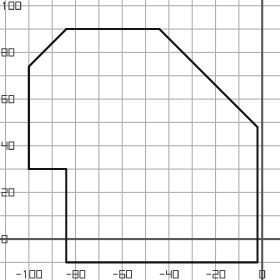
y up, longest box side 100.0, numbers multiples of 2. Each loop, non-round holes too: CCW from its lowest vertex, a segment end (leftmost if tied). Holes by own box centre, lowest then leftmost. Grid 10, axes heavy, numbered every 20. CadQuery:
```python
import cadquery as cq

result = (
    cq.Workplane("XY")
    .moveTo(-84.0, -10.0)
    .lineTo(-2.0, -10.0)
    .lineTo(-2.0, 48.0)
    .lineTo(-44.0, 90.0)
    .lineTo(-84.0, 90.0)
    .lineTo(-100.0, 74.0)
    .lineTo(-100.0, 30.0)
    .lineTo(-84.0, 30.0)
    .close()
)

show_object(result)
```